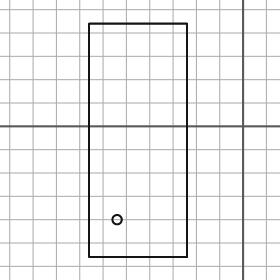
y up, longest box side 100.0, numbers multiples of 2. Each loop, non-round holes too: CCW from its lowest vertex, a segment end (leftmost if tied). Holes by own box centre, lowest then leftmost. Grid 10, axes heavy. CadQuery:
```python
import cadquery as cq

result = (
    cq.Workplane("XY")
    .moveTo(-66.0, -56.0)
    .lineTo(-24.0, -56.0)
    .lineTo(-24.0, 44.0)
    .lineTo(-66.0, 44.0)
    .close()
    .moveTo(-54.0, -40.0)
    .circle(2.0)
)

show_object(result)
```